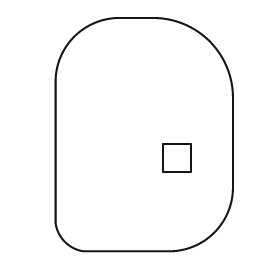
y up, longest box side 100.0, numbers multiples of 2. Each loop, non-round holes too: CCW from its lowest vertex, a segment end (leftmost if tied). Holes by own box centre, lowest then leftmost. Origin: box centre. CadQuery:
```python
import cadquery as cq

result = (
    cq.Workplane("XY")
    .moveTo(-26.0, -50.0)
    .lineTo(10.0, -50.0)
    .threePointArc((30.0, -42.0), (38.0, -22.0))
    .lineTo(38.0, 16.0)
    .threePointArc((28.0, 40.0), (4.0, 50.0))
    .lineTo(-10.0, 50.0)
    .threePointArc((-30.0, 42.0), (-38.0, 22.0))
    .lineTo(-38.0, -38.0)
    .threePointArc((-34.0, -46.0), (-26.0, -50.0))
    .close()
    .moveTo(8.0, -16.0)
    .lineTo(20.0, -16.0)
    .lineTo(20.0, -4.0)
    .lineTo(8.0, -4.0)
    .close()
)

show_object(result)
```